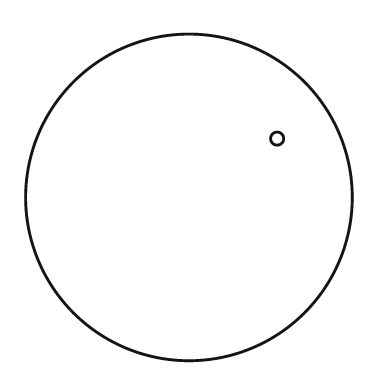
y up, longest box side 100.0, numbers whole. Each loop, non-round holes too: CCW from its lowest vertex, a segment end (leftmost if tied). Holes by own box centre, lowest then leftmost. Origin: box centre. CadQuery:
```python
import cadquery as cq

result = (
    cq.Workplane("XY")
    .moveTo(0.0, 0.0)
    .circle(50.0)
    .moveTo(27.0, 18.0)
    .circle(2.0)
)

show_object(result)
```